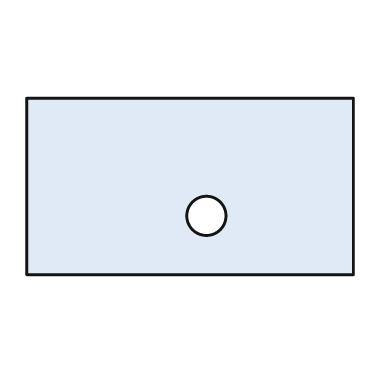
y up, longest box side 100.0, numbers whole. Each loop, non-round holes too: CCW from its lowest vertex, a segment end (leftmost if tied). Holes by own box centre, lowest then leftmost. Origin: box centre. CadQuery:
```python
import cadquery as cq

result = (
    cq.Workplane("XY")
    .moveTo(-50.0, -27.0)
    .lineTo(50.0, -27.0)
    .lineTo(50.0, 27.0)
    .lineTo(-50.0, 27.0)
    .close()
    .moveTo(5.0, -9.0)
    .circle(6.0)
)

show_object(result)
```